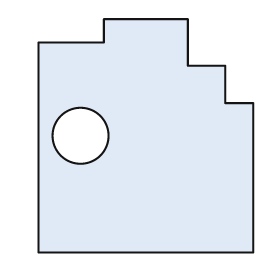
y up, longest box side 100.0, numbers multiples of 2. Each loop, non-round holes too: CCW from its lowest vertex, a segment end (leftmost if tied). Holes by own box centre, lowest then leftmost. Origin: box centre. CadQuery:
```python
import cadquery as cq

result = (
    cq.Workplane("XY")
    .moveTo(-46.0, -50.0)
    .lineTo(46.0, -50.0)
    .lineTo(46.0, 14.0)
    .lineTo(34.0, 14.0)
    .lineTo(34.0, 30.0)
    .lineTo(18.0, 30.0)
    .lineTo(18.0, 50.0)
    .lineTo(-18.0, 50.0)
    .lineTo(-18.0, 40.0)
    .lineTo(-46.0, 40.0)
    .close()
    .moveTo(-28.0, 0.0)
    .circle(12.0)
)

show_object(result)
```